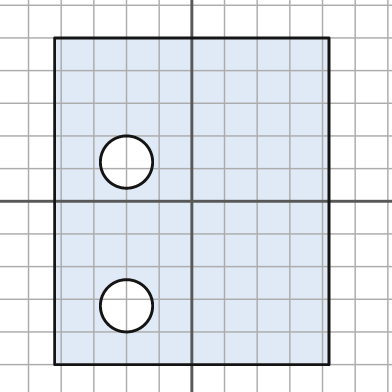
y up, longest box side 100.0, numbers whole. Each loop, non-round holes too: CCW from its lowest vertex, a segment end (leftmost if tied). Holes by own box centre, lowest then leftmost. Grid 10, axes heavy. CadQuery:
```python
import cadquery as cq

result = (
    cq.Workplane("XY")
    .moveTo(-42.0, -50.0)
    .lineTo(42.0, -50.0)
    .lineTo(42.0, 50.0)
    .lineTo(-42.0, 50.0)
    .close()
    .moveTo(-20.0, -32.0)
    .circle(8.0)
    .moveTo(-20.0, 12.0)
    .circle(8.0)
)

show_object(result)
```